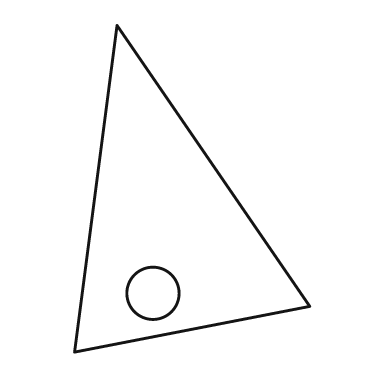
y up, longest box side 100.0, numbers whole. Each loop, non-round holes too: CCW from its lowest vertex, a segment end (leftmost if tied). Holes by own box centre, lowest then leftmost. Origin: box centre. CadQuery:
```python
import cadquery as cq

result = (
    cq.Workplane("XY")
    .moveTo(-36.0, -50.0)
    .lineTo(36.0, -36.0)
    .lineTo(-23.0, 50.0)
    .close()
    .moveTo(-12.0, -32.0)
    .circle(8.0)
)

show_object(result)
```